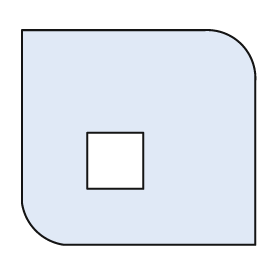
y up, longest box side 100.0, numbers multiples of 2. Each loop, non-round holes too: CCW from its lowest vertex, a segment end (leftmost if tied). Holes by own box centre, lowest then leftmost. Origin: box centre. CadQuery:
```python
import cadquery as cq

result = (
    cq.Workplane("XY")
    .moveTo(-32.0, -46.0)
    .lineTo(50.0, -46.0)
    .lineTo(50.0, 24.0)
    .threePointArc((44.0, 40.0), (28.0, 46.0))
    .lineTo(-50.0, 46.0)
    .lineTo(-50.0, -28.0)
    .threePointArc((-44.0, -40.0), (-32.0, -46.0))
    .close()
    .moveTo(-22.0, -22.0)
    .lineTo(2.0, -22.0)
    .lineTo(2.0, 2.0)
    .lineTo(-22.0, 2.0)
    .close()
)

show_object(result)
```